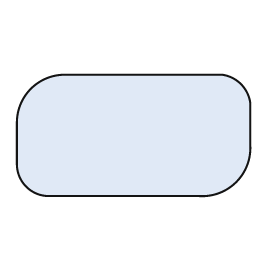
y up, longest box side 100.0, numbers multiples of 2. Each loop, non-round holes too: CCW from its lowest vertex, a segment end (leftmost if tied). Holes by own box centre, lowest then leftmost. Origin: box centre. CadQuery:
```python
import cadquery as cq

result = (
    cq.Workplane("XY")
    .moveTo(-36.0, -26.0)
    .lineTo(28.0, -26.0)
    .threePointArc((44.0, -20.0), (50.0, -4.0))
    .lineTo(50.0, 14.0)
    .threePointArc((46.0, 22.0), (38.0, 26.0))
    .lineTo(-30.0, 26.0)
    .threePointArc((-44.0, 20.0), (-50.0, 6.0))
    .lineTo(-50.0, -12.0)
    .threePointArc((-46.0, -22.0), (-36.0, -26.0))
    .close()
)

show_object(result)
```